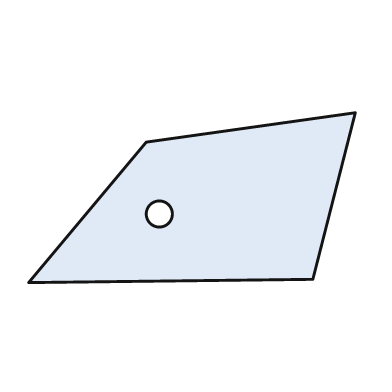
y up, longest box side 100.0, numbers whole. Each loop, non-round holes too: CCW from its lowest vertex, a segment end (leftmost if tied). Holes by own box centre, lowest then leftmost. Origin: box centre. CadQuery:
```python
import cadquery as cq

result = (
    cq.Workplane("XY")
    .moveTo(-50.0, -26.0)
    .lineTo(37.0, -25.0)
    .lineTo(50.0, 26.0)
    .lineTo(-14.0, 17.0)
    .close()
    .moveTo(-10.0, -5.0)
    .circle(4.0)
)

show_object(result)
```